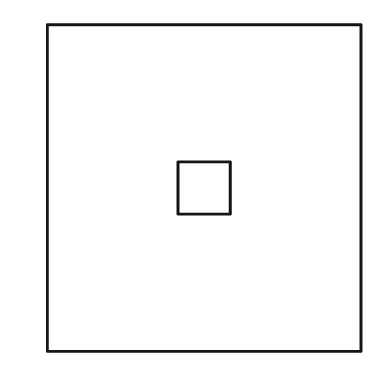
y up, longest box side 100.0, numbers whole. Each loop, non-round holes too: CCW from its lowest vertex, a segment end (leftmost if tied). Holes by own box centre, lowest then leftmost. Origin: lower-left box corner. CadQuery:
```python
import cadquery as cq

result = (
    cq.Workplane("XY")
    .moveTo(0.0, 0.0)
    .lineTo(96.0, 0.0)
    .lineTo(96.0, 100.0)
    .lineTo(0.0, 100.0)
    .close()
    .moveTo(40.0, 42.0)
    .lineTo(56.0, 42.0)
    .lineTo(56.0, 58.0)
    .lineTo(40.0, 58.0)
    .close()
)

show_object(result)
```